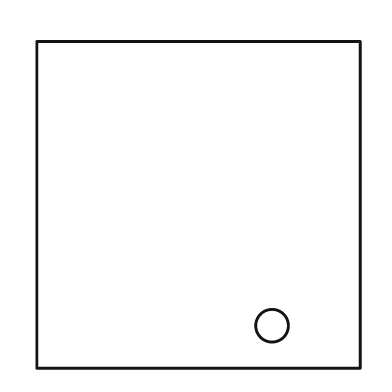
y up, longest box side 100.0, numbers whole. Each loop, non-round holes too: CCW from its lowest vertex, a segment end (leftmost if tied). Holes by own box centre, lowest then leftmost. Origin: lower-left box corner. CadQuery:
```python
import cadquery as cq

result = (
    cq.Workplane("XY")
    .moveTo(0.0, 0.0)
    .lineTo(99.0, 0.0)
    .lineTo(99.0, 100.0)
    .lineTo(0.0, 100.0)
    .close()
    .moveTo(72.0, 13.0)
    .circle(5.0)
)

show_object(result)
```